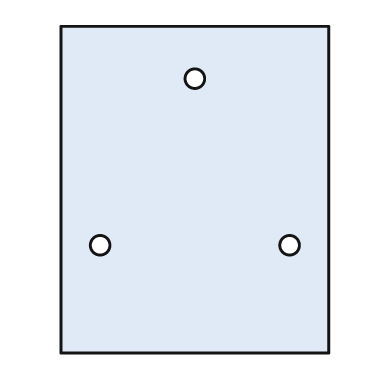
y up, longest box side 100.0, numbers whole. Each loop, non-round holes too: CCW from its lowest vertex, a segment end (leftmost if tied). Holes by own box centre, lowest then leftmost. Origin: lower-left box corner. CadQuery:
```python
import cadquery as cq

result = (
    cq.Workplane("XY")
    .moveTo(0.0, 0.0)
    .lineTo(82.0, 0.0)
    .lineTo(82.0, 100.0)
    .lineTo(0.0, 100.0)
    .close()
    .moveTo(12.0, 33.0)
    .circle(3.0)
    .moveTo(70.0, 33.0)
    .circle(3.0)
    .moveTo(41.0, 84.0)
    .circle(3.0)
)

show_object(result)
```